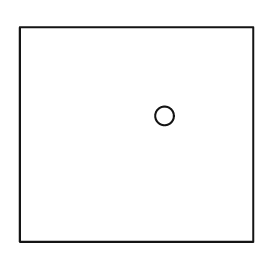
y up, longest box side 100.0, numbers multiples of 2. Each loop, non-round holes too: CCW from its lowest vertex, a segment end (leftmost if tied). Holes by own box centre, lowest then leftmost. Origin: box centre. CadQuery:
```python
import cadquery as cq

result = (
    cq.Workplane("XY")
    .moveTo(-50.0, -46.0)
    .lineTo(50.0, -46.0)
    .lineTo(50.0, 46.0)
    .lineTo(-50.0, 46.0)
    .close()
    .moveTo(12.0, 8.0)
    .circle(4.0)
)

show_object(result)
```